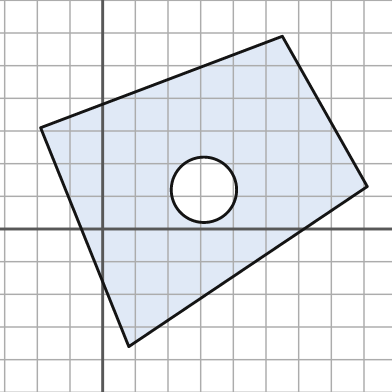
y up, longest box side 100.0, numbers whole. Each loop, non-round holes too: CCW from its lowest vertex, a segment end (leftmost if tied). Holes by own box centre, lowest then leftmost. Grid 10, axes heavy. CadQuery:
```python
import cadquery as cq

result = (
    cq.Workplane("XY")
    .moveTo(8.0, -36.0)
    .lineTo(81.0, 13.0)
    .lineTo(55.0, 59.0)
    .lineTo(-19.0, 31.0)
    .close()
    .moveTo(31.0, 12.0)
    .circle(10.0)
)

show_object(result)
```